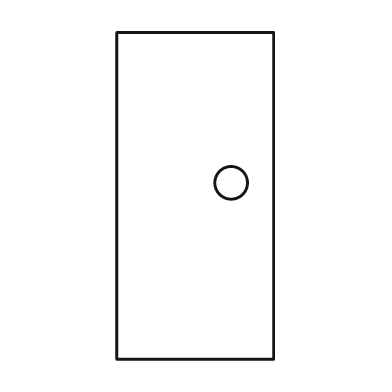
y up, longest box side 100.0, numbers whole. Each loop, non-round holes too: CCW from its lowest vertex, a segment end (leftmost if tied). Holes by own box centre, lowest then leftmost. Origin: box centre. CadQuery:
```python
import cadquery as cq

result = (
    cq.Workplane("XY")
    .moveTo(-24.0, -50.0)
    .lineTo(24.0, -50.0)
    .lineTo(24.0, 50.0)
    .lineTo(-24.0, 50.0)
    .close()
    .moveTo(11.0, 4.0)
    .circle(5.0)
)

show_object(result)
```